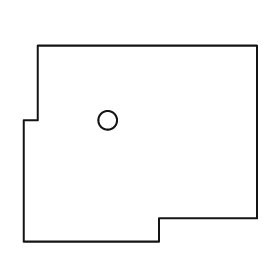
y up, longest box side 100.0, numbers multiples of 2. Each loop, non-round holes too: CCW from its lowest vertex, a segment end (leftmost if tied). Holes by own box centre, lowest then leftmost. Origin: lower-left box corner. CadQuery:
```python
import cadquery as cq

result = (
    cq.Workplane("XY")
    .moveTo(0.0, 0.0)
    .lineTo(58.0, 0.0)
    .lineTo(58.0, 10.0)
    .lineTo(100.0, 10.0)
    .lineTo(100.0, 84.0)
    .lineTo(6.0, 84.0)
    .lineTo(6.0, 52.0)
    .lineTo(0.0, 52.0)
    .close()
    .moveTo(36.0, 52.0)
    .circle(4.0)
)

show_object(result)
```